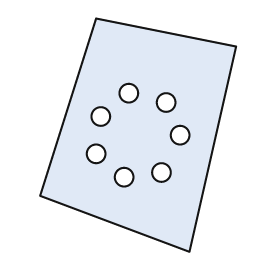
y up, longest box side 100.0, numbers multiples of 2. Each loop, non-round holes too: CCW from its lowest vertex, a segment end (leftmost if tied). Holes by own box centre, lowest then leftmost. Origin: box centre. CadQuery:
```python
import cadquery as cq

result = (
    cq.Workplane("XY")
    .moveTo(22.0, -50.0)
    .lineTo(42.0, 38.0)
    .lineTo(-18.0, 50.0)
    .lineTo(-42.0, -26.0)
    .close()
    .moveTo(-6.0, -18.0)
    .circle(4.0)
    .moveTo(10.0, -16.0)
    .circle(4.0)
    .moveTo(-18.0, -8.0)
    .circle(4.0)
    .moveTo(18.0, 0.0)
    .circle(4.0)
    .moveTo(-16.0, 8.0)
    .circle(4.0)
    .moveTo(12.0, 14.0)
    .circle(4.0)
    .moveTo(-4.0, 18.0)
    .circle(4.0)
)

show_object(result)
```